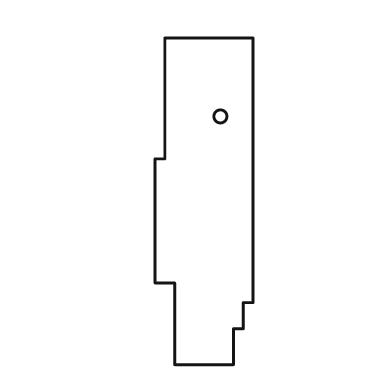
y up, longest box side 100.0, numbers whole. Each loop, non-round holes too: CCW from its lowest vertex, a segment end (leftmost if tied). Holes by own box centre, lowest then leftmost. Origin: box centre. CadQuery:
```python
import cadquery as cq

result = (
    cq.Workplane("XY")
    .moveTo(-9.0, -50.0)
    .lineTo(9.0, -50.0)
    .lineTo(9.0, -39.0)
    .lineTo(12.0, -39.0)
    .lineTo(12.0, -31.0)
    .lineTo(15.0, -31.0)
    .lineTo(15.0, 50.0)
    .lineTo(-12.0, 50.0)
    .lineTo(-12.0, 13.0)
    .lineTo(-15.0, 13.0)
    .lineTo(-15.0, -25.0)
    .lineTo(-9.0, -25.0)
    .close()
    .moveTo(5.0, 26.0)
    .circle(2.0)
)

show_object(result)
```